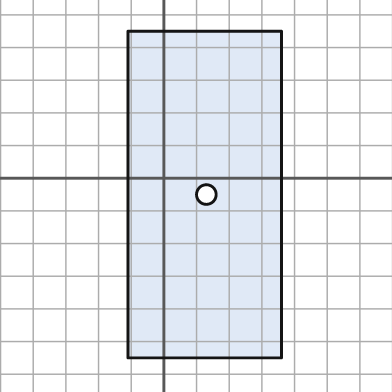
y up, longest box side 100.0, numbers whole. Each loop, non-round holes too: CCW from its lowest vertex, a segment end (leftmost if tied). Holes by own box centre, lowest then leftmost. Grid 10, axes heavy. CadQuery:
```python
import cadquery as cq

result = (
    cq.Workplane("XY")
    .moveTo(-11.0, -55.0)
    .lineTo(36.0, -55.0)
    .lineTo(36.0, 45.0)
    .lineTo(-11.0, 45.0)
    .close()
    .moveTo(13.0, -5.0)
    .circle(3.0)
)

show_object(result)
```